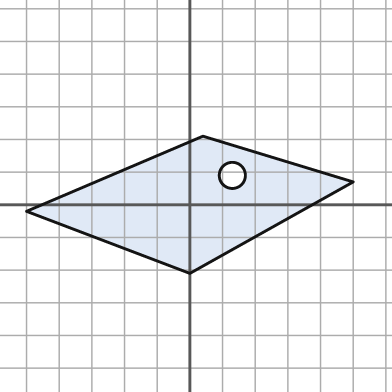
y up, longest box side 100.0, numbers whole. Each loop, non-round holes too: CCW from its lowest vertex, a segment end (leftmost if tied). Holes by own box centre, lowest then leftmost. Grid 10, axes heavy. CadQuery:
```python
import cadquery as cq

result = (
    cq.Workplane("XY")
    .moveTo(0.0, -21.0)
    .lineTo(50.0, 7.0)
    .lineTo(4.0, 21.0)
    .lineTo(-50.0, -2.0)
    .close()
    .moveTo(13.0, 9.0)
    .circle(4.0)
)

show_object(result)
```